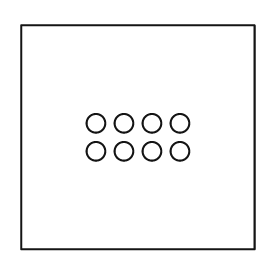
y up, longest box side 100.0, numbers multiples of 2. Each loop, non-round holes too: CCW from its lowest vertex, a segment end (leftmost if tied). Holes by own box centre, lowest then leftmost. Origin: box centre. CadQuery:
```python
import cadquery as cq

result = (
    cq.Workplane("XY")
    .moveTo(-50.0, -48.0)
    .lineTo(50.0, -48.0)
    .lineTo(50.0, 48.0)
    .lineTo(-50.0, 48.0)
    .close()
    .moveTo(-18.0, -6.0)
    .circle(4.0)
    .moveTo(-6.0, -6.0)
    .circle(4.0)
    .moveTo(6.0, -6.0)
    .circle(4.0)
    .moveTo(18.0, -6.0)
    .circle(4.0)
    .moveTo(-18.0, 6.0)
    .circle(4.0)
    .moveTo(-6.0, 6.0)
    .circle(4.0)
    .moveTo(6.0, 6.0)
    .circle(4.0)
    .moveTo(18.0, 6.0)
    .circle(4.0)
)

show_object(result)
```